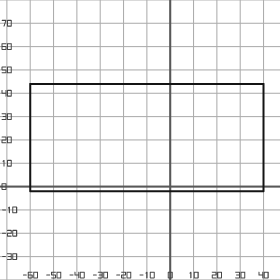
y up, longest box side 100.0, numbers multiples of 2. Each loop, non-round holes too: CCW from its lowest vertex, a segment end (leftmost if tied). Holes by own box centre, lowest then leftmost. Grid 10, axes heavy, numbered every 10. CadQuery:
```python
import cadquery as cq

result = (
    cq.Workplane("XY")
    .moveTo(-60.0, -2.0)
    .lineTo(40.0, -2.0)
    .lineTo(40.0, 44.0)
    .lineTo(-60.0, 44.0)
    .close()
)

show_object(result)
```